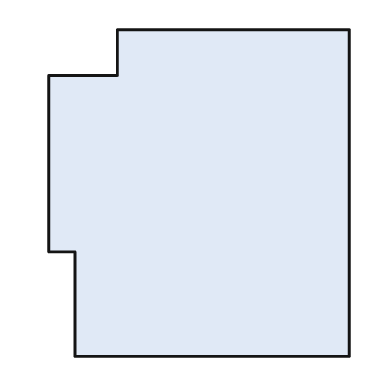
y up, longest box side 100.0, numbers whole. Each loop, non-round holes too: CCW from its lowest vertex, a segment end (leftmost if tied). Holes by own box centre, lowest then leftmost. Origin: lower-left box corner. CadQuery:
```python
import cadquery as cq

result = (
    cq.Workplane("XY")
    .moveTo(8.0, 0.0)
    .lineTo(92.0, 0.0)
    .lineTo(92.0, 100.0)
    .lineTo(21.0, 100.0)
    .lineTo(21.0, 86.0)
    .lineTo(0.0, 86.0)
    .lineTo(0.0, 32.0)
    .lineTo(8.0, 32.0)
    .close()
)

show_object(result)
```